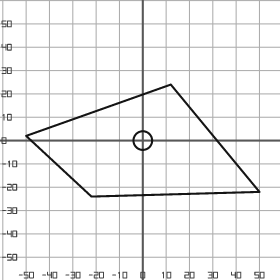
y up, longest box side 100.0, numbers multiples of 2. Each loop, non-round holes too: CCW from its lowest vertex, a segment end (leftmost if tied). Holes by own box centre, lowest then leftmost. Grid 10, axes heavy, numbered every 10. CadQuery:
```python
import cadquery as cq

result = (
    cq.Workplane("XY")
    .moveTo(-22.0, -24.0)
    .lineTo(50.0, -22.0)
    .lineTo(12.0, 24.0)
    .lineTo(-50.0, 2.0)
    .close()
    .moveTo(0.0, 0.0)
    .circle(4.0)
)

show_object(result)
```